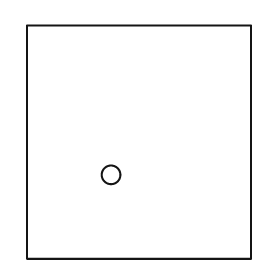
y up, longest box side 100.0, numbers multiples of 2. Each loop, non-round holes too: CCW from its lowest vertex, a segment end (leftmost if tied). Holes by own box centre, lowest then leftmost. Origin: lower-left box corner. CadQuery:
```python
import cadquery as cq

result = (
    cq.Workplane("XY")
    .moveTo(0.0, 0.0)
    .lineTo(96.0, 0.0)
    .lineTo(96.0, 100.0)
    .lineTo(0.0, 100.0)
    .close()
    .moveTo(36.0, 36.0)
    .circle(4.0)
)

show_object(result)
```